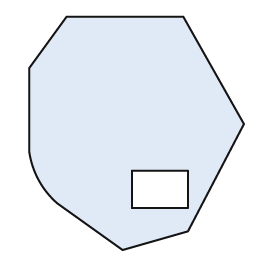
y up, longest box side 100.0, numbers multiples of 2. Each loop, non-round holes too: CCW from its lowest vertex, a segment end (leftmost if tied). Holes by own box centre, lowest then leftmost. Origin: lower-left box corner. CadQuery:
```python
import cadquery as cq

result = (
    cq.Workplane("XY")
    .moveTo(40.0, 0.0)
    .lineTo(68.0, 8.0)
    .lineTo(92.0, 54.0)
    .lineTo(66.0, 100.0)
    .lineTo(16.0, 100.0)
    .lineTo(0.0, 78.0)
    .lineTo(0.0, 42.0)
    .threePointArc((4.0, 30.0), (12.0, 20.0))
    .close()
    .moveTo(44.0, 18.0)
    .lineTo(68.0, 18.0)
    .lineTo(68.0, 34.0)
    .lineTo(44.0, 34.0)
    .close()
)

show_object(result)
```